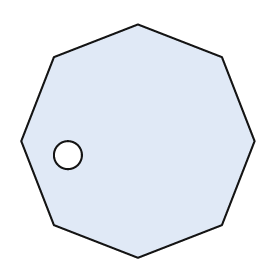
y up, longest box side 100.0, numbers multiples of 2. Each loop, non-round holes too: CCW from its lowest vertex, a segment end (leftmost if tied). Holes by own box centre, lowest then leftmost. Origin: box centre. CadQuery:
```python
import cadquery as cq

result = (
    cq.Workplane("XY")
    .moveTo(0.0, -50.0)
    .lineTo(36.0, -36.0)
    .lineTo(50.0, 0.0)
    .lineTo(36.0, 36.0)
    .lineTo(0.0, 50.0)
    .lineTo(-36.0, 36.0)
    .lineTo(-50.0, 0.0)
    .lineTo(-36.0, -36.0)
    .close()
    .moveTo(-30.0, -6.0)
    .circle(6.0)
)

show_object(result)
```